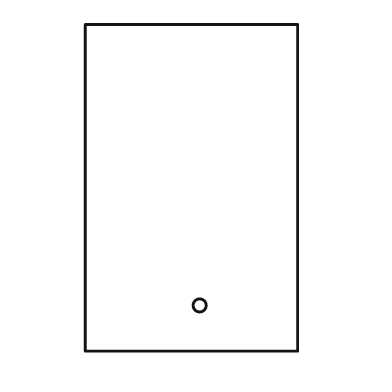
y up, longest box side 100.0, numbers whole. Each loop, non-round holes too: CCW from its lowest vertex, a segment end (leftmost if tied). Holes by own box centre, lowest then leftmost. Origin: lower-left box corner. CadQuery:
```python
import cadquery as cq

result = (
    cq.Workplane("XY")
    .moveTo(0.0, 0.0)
    .lineTo(65.0, 0.0)
    .lineTo(65.0, 100.0)
    .lineTo(0.0, 100.0)
    .close()
    .moveTo(35.0, 14.0)
    .circle(2.0)
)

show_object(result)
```